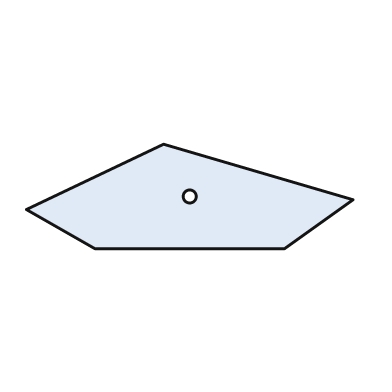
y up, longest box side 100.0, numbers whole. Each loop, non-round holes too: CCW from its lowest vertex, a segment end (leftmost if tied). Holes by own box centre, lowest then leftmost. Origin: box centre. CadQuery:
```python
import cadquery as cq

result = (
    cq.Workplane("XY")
    .moveTo(-29.0, -16.0)
    .lineTo(29.0, -16.0)
    .lineTo(50.0, -1.0)
    .lineTo(-8.0, 16.0)
    .lineTo(-50.0, -4.0)
    .close()
    .moveTo(0.0, 0.0)
    .circle(2.0)
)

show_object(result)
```